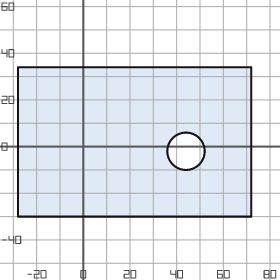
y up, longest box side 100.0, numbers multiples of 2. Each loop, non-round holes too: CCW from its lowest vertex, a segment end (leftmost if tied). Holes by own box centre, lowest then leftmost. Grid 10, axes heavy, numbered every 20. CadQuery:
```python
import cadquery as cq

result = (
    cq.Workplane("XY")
    .moveTo(-28.0, -30.0)
    .lineTo(72.0, -30.0)
    .lineTo(72.0, 34.0)
    .lineTo(-28.0, 34.0)
    .close()
    .moveTo(44.0, -2.0)
    .circle(8.0)
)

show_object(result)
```